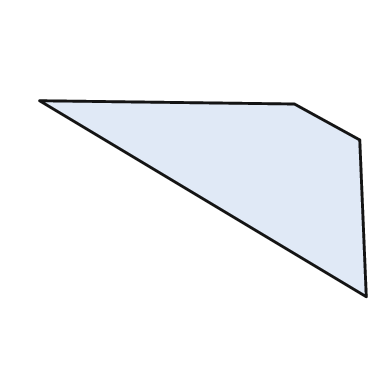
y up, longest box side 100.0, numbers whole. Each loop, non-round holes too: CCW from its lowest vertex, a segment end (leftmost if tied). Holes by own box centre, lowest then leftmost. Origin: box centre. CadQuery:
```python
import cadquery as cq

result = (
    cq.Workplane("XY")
    .moveTo(50.0, -30.0)
    .lineTo(48.0, 18.0)
    .lineTo(28.0, 29.0)
    .lineTo(-50.0, 30.0)
    .close()
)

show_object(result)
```